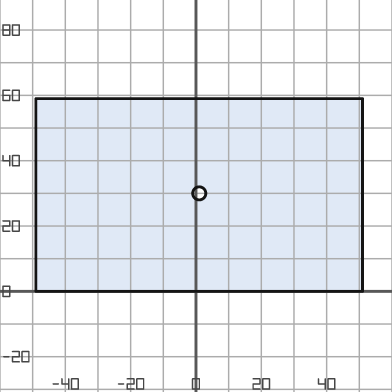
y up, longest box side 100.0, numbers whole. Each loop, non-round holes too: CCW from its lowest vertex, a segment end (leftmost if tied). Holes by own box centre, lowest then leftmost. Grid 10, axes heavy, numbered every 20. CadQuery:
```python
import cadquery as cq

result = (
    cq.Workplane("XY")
    .moveTo(-49.0, 0.0)
    .lineTo(51.0, 0.0)
    .lineTo(51.0, 59.0)
    .lineTo(-49.0, 59.0)
    .close()
    .moveTo(1.0, 30.0)
    .circle(2.0)
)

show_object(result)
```